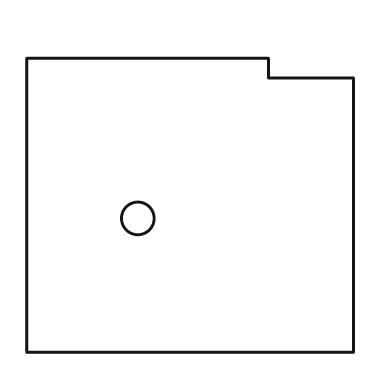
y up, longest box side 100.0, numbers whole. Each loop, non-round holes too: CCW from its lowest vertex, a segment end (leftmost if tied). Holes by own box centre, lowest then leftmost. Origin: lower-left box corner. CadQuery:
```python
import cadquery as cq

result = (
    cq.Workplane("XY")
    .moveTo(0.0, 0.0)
    .lineTo(100.0, 0.0)
    .lineTo(100.0, 84.0)
    .lineTo(74.0, 84.0)
    .lineTo(74.0, 90.0)
    .lineTo(0.0, 90.0)
    .close()
    .moveTo(34.0, 41.0)
    .circle(5.0)
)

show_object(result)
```